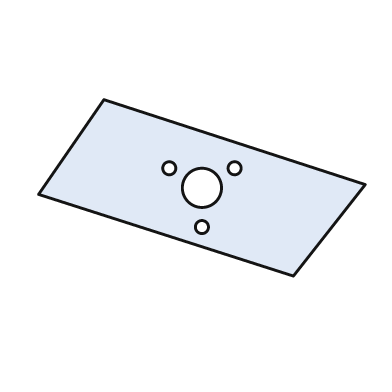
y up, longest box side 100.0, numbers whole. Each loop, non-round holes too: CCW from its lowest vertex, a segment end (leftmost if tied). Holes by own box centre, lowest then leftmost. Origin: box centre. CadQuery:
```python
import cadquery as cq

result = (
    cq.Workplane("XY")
    .moveTo(28.0, -27.0)
    .lineTo(50.0, 1.0)
    .lineTo(-30.0, 27.0)
    .lineTo(-50.0, -2.0)
    .close()
    .moveTo(0.0, -12.0)
    .circle(2.0)
    .moveTo(0.0, 0.0)
    .circle(6.0)
    .moveTo(-10.0, 6.0)
    .circle(2.0)
    .moveTo(10.0, 6.0)
    .circle(2.0)
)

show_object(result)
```